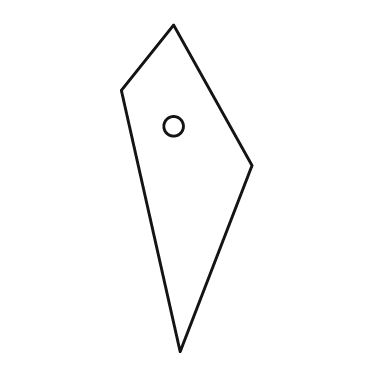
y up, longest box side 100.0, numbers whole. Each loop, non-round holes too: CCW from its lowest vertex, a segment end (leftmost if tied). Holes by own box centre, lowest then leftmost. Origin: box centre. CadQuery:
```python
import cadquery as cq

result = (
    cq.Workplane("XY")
    .moveTo(-2.0, -50.0)
    .lineTo(20.0, 7.0)
    .lineTo(-4.0, 50.0)
    .lineTo(-20.0, 30.0)
    .close()
    .moveTo(-4.0, 19.0)
    .circle(3.0)
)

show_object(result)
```